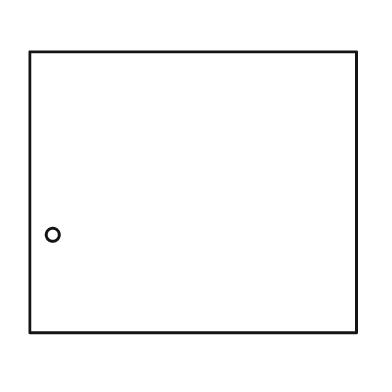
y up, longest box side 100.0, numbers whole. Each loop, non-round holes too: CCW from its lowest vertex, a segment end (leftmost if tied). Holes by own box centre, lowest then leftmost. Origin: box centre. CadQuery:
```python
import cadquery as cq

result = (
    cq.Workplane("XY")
    .moveTo(-50.0, -43.0)
    .lineTo(50.0, -43.0)
    .lineTo(50.0, 43.0)
    .lineTo(-50.0, 43.0)
    .close()
    .moveTo(-43.0, -13.0)
    .circle(2.0)
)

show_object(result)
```